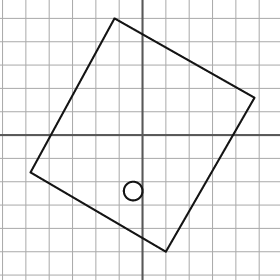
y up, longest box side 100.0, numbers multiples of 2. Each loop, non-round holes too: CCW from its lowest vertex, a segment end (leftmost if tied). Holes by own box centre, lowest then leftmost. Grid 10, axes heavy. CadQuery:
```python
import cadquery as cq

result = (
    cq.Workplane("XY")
    .moveTo(10.0, -50.0)
    .lineTo(48.0, 16.0)
    .lineTo(-12.0, 50.0)
    .lineTo(-48.0, -16.0)
    .close()
    .moveTo(-4.0, -24.0)
    .circle(4.0)
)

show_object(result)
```